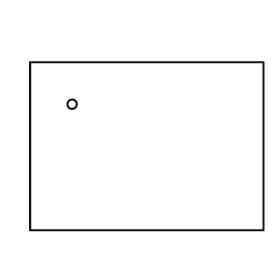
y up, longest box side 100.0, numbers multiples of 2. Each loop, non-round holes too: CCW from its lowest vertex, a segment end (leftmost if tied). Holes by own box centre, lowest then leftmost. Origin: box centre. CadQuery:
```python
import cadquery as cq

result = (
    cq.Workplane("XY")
    .moveTo(-50.0, -36.0)
    .lineTo(50.0, -36.0)
    .lineTo(50.0, 36.0)
    .lineTo(-50.0, 36.0)
    .close()
    .moveTo(-32.0, 18.0)
    .circle(2.0)
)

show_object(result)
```